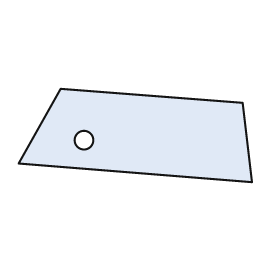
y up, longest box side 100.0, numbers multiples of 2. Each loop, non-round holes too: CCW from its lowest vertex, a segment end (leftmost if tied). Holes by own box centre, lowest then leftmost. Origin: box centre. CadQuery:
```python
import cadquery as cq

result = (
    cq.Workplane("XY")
    .moveTo(50.0, -20.0)
    .lineTo(46.0, 14.0)
    .lineTo(-32.0, 20.0)
    .lineTo(-50.0, -12.0)
    .close()
    .moveTo(-22.0, -2.0)
    .circle(4.0)
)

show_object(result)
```